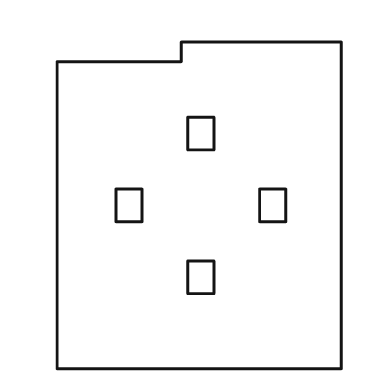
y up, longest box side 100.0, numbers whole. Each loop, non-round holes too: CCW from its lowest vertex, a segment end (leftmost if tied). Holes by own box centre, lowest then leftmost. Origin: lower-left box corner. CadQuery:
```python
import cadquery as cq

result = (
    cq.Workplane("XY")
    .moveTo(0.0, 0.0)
    .lineTo(87.0, 0.0)
    .lineTo(87.0, 100.0)
    .lineTo(38.0, 100.0)
    .lineTo(38.0, 94.0)
    .lineTo(0.0, 94.0)
    .close()
    .moveTo(40.0, 23.0)
    .lineTo(48.0, 23.0)
    .lineTo(48.0, 33.0)
    .lineTo(40.0, 33.0)
    .close()
    .moveTo(18.0, 45.0)
    .lineTo(26.0, 45.0)
    .lineTo(26.0, 55.0)
    .lineTo(18.0, 55.0)
    .close()
    .moveTo(62.0, 45.0)
    .lineTo(70.0, 45.0)
    .lineTo(70.0, 55.0)
    .lineTo(62.0, 55.0)
    .close()
    .moveTo(40.0, 67.0)
    .lineTo(48.0, 67.0)
    .lineTo(48.0, 77.0)
    .lineTo(40.0, 77.0)
    .close()
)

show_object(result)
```